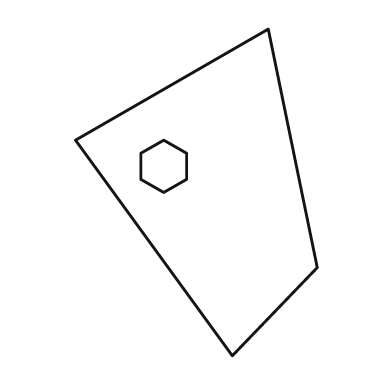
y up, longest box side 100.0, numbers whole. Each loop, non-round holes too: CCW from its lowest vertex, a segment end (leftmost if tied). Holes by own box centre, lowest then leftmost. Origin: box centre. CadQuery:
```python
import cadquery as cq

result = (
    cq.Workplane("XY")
    .moveTo(11.0, -50.0)
    .lineTo(37.0, -23.0)
    .lineTo(22.0, 50.0)
    .lineTo(-37.0, 16.0)
    .close()
    .moveTo(-10.0, 0.0)
    .lineTo(-3.0, 4.0)
    .lineTo(-3.0, 12.0)
    .lineTo(-10.0, 16.0)
    .lineTo(-17.0, 12.0)
    .lineTo(-17.0, 4.0)
    .close()
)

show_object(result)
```